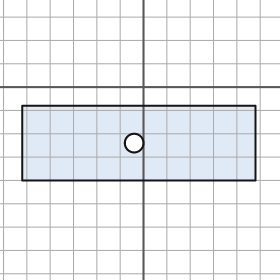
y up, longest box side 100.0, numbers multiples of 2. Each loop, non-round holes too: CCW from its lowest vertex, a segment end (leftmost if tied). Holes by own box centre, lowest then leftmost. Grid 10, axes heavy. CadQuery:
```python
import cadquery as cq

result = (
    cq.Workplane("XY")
    .moveTo(-52.0, -40.0)
    .lineTo(48.0, -40.0)
    .lineTo(48.0, -8.0)
    .lineTo(-52.0, -8.0)
    .close()
    .moveTo(-4.0, -24.0)
    .circle(4.0)
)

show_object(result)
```